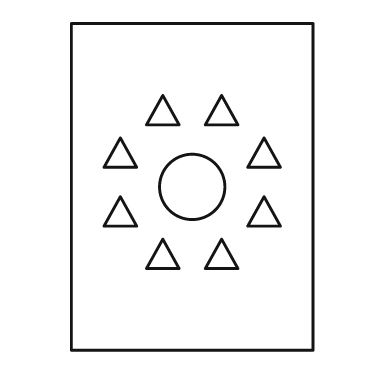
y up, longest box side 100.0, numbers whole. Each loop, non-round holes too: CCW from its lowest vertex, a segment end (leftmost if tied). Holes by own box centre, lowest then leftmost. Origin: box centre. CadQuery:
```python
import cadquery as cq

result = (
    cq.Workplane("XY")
    .moveTo(-37.0, -50.0)
    .lineTo(37.0, -50.0)
    .lineTo(37.0, 50.0)
    .lineTo(-37.0, 50.0)
    .close()
    .moveTo(-14.0, -25.0)
    .lineTo(-4.0, -25.0)
    .lineTo(-9.0, -16.0)
    .close()
    .moveTo(4.0, -25.0)
    .lineTo(14.0, -25.0)
    .lineTo(9.0, -16.0)
    .close()
    .moveTo(-27.0, -12.0)
    .lineTo(-17.0, -12.0)
    .lineTo(-22.0, -3.0)
    .close()
    .moveTo(17.0, -12.0)
    .lineTo(27.0, -12.0)
    .lineTo(22.0, -3.0)
    .close()
    .moveTo(0.0, 0.0)
    .circle(10.0)
    .moveTo(-27.0, 6.0)
    .lineTo(-17.0, 6.0)
    .lineTo(-22.0, 15.0)
    .close()
    .moveTo(17.0, 6.0)
    .lineTo(27.0, 6.0)
    .lineTo(22.0, 15.0)
    .close()
    .moveTo(-14.0, 19.0)
    .lineTo(-4.0, 19.0)
    .lineTo(-9.0, 28.0)
    .close()
    .moveTo(4.0, 19.0)
    .lineTo(14.0, 19.0)
    .lineTo(9.0, 28.0)
    .close()
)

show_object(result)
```